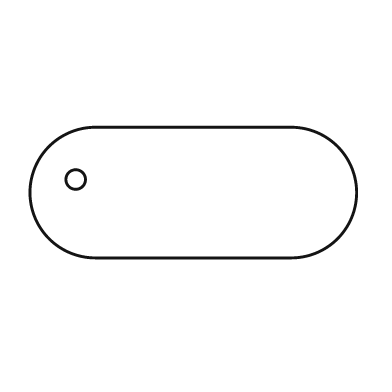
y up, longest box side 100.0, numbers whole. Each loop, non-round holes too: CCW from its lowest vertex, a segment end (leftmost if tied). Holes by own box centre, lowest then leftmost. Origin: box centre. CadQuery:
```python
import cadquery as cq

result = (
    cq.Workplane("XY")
    .moveTo(-30.0, -20.0)
    .lineTo(30.0, -20.0)
    .threePointArc((50.0, 0.0), (30.0, 20.0))
    .lineTo(-30.0, 20.0)
    .threePointArc((-50.0, 0.0), (-30.0, -20.0))
    .close()
    .moveTo(-36.0, 4.0)
    .circle(3.0)
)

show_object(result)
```